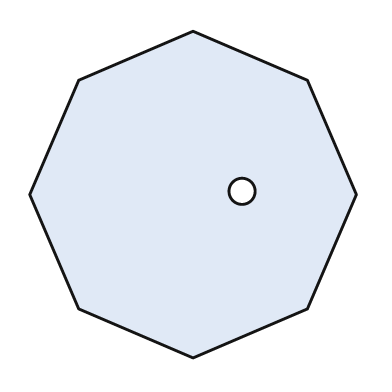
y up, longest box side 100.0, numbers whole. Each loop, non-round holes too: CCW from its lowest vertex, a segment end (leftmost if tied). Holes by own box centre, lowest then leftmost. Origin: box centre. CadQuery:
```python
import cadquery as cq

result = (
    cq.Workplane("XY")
    .moveTo(0.0, -50.0)
    .lineTo(35.0, -35.0)
    .lineTo(50.0, 0.0)
    .lineTo(35.0, 35.0)
    .lineTo(0.0, 50.0)
    .lineTo(-35.0, 35.0)
    .lineTo(-50.0, 0.0)
    .lineTo(-35.0, -35.0)
    .close()
    .moveTo(15.0, 1.0)
    .circle(4.0)
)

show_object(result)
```